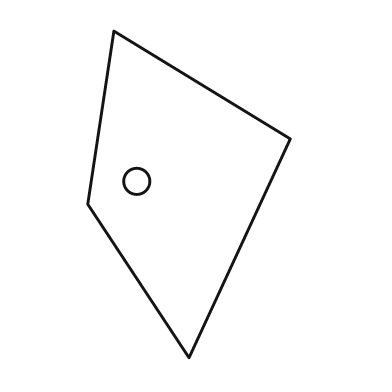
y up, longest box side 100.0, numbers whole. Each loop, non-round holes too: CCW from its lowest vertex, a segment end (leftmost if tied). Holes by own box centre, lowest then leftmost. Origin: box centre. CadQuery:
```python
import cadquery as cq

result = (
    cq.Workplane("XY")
    .moveTo(0.0, -50.0)
    .lineTo(31.0, 17.0)
    .lineTo(-23.0, 50.0)
    .lineTo(-31.0, -3.0)
    .close()
    .moveTo(-16.0, 4.0)
    .circle(4.0)
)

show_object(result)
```